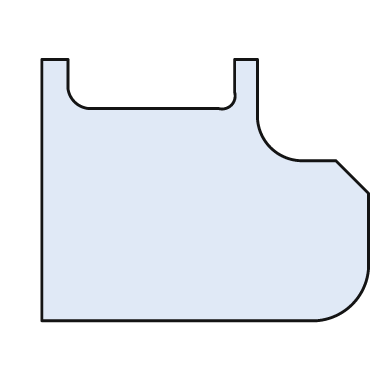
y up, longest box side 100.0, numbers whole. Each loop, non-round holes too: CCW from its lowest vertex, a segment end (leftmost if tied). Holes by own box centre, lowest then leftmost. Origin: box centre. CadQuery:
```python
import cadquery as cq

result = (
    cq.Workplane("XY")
    .moveTo(-50.0, -40.0)
    .lineTo(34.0, -40.0)
    .threePointArc((45.0, -35.0), (50.0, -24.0))
    .lineTo(50.0, -1.0)
    .lineTo(40.0, 9.0)
    .lineTo(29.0, 9.0)
    .threePointArc((20.0, 13.0), (16.0, 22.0))
    .lineTo(16.0, 40.0)
    .lineTo(9.0, 40.0)
    .lineTo(9.0, 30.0)
    .threePointArc((8.0, 26.0), (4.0, 25.0))
    .lineTo(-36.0, 25.0)
    .threePointArc((-40.0, 27.0), (-42.0, 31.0))
    .lineTo(-42.0, 40.0)
    .lineTo(-50.0, 40.0)
    .close()
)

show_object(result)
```